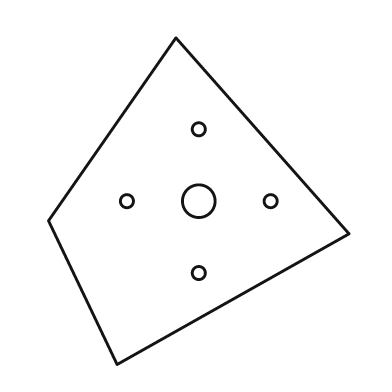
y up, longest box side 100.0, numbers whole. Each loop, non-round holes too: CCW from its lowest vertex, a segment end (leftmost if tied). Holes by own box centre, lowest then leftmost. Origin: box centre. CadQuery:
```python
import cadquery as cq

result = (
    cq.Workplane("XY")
    .moveTo(-25.0, -50.0)
    .lineTo(46.0, -10.0)
    .lineTo(-7.0, 50.0)
    .lineTo(-46.0, -6.0)
    .close()
    .moveTo(0.0, -22.0)
    .circle(2.0)
    .moveTo(-22.0, 0.0)
    .circle(2.0)
    .moveTo(0.0, 0.0)
    .circle(5.0)
    .moveTo(22.0, 0.0)
    .circle(2.0)
    .moveTo(0.0, 22.0)
    .circle(2.0)
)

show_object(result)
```